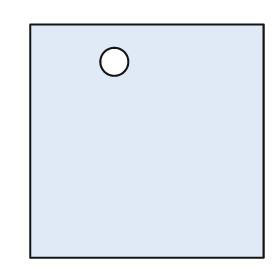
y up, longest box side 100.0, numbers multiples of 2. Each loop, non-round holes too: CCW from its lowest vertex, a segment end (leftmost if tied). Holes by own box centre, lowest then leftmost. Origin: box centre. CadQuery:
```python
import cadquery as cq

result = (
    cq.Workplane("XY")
    .moveTo(-50.0, -50.0)
    .lineTo(50.0, -50.0)
    .lineTo(50.0, 50.0)
    .lineTo(-50.0, 50.0)
    .close()
    .moveTo(-14.0, 34.0)
    .circle(6.0)
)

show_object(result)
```